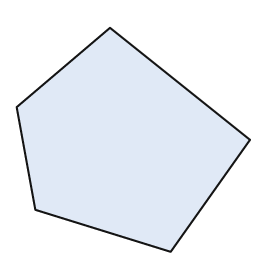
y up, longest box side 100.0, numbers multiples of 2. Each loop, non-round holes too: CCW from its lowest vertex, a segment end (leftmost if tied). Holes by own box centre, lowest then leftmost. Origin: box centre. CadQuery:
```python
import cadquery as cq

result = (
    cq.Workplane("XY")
    .moveTo(16.0, -48.0)
    .lineTo(50.0, 0.0)
    .lineTo(-10.0, 48.0)
    .lineTo(-50.0, 14.0)
    .lineTo(-42.0, -30.0)
    .close()
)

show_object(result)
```